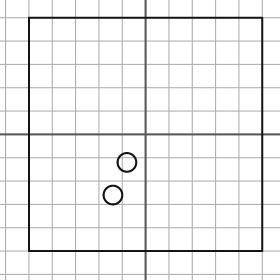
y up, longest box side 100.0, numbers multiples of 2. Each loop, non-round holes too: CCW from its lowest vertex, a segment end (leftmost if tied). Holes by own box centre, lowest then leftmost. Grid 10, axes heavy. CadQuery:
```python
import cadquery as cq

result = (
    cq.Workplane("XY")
    .moveTo(-50.0, -50.0)
    .lineTo(50.0, -50.0)
    .lineTo(50.0, 50.0)
    .lineTo(-50.0, 50.0)
    .close()
    .moveTo(-14.0, -26.0)
    .circle(4.0)
    .moveTo(-8.0, -12.0)
    .circle(4.0)
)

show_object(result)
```